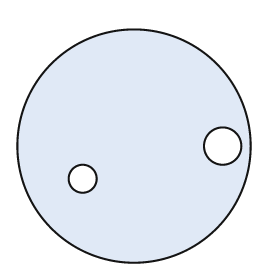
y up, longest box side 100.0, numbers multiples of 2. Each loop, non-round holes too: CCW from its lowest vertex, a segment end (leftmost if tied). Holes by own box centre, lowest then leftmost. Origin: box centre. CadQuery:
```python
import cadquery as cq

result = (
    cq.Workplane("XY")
    .moveTo(0.0, 0.0)
    .circle(50.0)
    .moveTo(-22.0, -14.0)
    .circle(6.0)
    .moveTo(38.0, 0.0)
    .circle(8.0)
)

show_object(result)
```